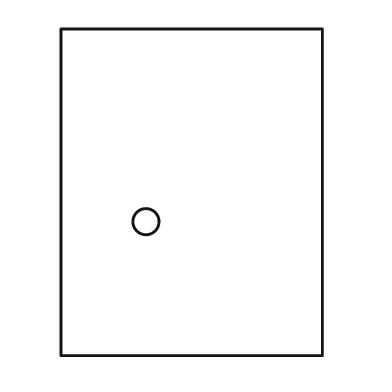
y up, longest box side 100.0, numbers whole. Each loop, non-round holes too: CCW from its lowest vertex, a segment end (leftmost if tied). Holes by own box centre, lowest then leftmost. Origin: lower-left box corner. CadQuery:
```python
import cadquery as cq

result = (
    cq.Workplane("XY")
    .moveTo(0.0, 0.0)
    .lineTo(80.0, 0.0)
    .lineTo(80.0, 100.0)
    .lineTo(0.0, 100.0)
    .close()
    .moveTo(26.0, 41.0)
    .circle(4.0)
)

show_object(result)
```